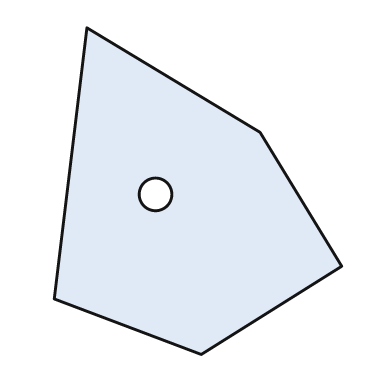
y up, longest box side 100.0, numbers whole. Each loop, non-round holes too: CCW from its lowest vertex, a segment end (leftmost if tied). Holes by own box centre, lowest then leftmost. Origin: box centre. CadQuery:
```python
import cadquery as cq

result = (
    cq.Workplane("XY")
    .moveTo(1.0, -50.0)
    .lineTo(44.0, -23.0)
    .lineTo(19.0, 18.0)
    .lineTo(-34.0, 50.0)
    .lineTo(-44.0, -33.0)
    .close()
    .moveTo(-13.0, -1.0)
    .circle(5.0)
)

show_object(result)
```